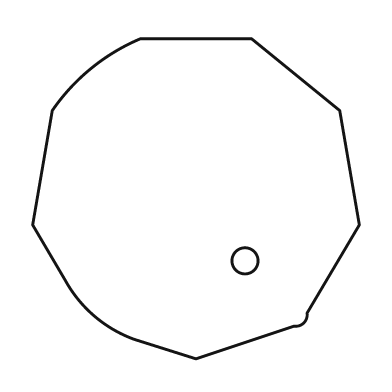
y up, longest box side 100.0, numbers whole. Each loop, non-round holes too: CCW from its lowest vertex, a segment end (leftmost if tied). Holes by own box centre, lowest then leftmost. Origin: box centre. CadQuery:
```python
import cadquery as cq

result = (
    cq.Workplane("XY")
    .moveTo(0.0, -49.0)
    .lineTo(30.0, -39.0)
    .threePointArc((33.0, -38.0), (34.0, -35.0))
    .lineTo(50.0, -8.0)
    .lineTo(44.0, 27.0)
    .lineTo(17.0, 49.0)
    .lineTo(-17.0, 49.0)
    .threePointArc((-32.0, 40.0), (-44.0, 27.0))
    .lineTo(-50.0, -8.0)
    .lineTo(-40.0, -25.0)
    .threePointArc((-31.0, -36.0), (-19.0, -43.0))
    .close()
    .moveTo(15.0, -19.0)
    .circle(4.0)
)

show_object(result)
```